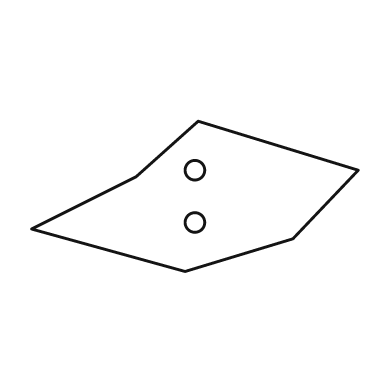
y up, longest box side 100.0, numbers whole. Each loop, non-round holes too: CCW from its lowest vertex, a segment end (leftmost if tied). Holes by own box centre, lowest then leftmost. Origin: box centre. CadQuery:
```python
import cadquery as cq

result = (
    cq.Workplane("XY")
    .moveTo(-3.0, -23.0)
    .lineTo(30.0, -13.0)
    .lineTo(50.0, 8.0)
    .lineTo(1.0, 23.0)
    .lineTo(-18.0, 6.0)
    .lineTo(-50.0, -10.0)
    .close()
    .moveTo(0.0, -8.0)
    .circle(3.0)
    .moveTo(0.0, 8.0)
    .circle(3.0)
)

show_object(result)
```